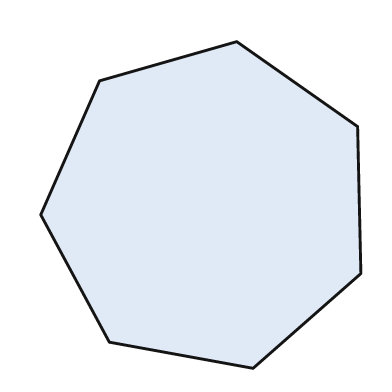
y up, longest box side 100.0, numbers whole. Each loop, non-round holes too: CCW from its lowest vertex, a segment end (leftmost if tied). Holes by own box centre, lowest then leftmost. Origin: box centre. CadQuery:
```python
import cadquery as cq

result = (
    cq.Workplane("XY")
    .moveTo(16.0, -50.0)
    .lineTo(49.0, -21.0)
    .lineTo(48.0, 24.0)
    .lineTo(11.0, 50.0)
    .lineTo(-31.0, 38.0)
    .lineTo(-49.0, -3.0)
    .lineTo(-28.0, -42.0)
    .close()
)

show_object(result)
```